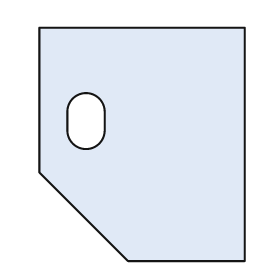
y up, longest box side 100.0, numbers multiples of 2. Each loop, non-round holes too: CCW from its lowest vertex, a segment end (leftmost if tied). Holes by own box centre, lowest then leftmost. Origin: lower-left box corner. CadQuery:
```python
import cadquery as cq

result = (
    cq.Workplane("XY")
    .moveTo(38.0, 0.0)
    .lineTo(88.0, 0.0)
    .lineTo(88.0, 100.0)
    .lineTo(0.0, 100.0)
    .lineTo(0.0, 38.0)
    .close()
    .moveTo(12.0, 56.0)
    .threePointArc((20.0, 48.0), (28.0, 56.0))
    .lineTo(28.0, 64.0)
    .threePointArc((20.0, 72.0), (12.0, 64.0))
    .close()
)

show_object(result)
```